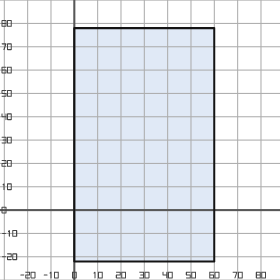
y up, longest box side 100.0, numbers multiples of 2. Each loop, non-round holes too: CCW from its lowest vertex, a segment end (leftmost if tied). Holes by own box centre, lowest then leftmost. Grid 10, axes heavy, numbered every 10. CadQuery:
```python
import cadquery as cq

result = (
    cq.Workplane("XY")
    .moveTo(0.0, -22.0)
    .lineTo(60.0, -22.0)
    .lineTo(60.0, 78.0)
    .lineTo(0.0, 78.0)
    .close()
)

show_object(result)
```